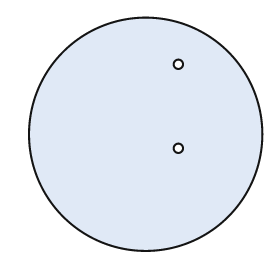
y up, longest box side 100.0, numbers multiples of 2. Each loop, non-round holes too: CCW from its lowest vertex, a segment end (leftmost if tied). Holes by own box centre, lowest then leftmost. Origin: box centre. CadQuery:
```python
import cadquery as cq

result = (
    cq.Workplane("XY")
    .moveTo(0.0, 0.0)
    .circle(50.0)
    .moveTo(14.0, -6.0)
    .circle(2.0)
    .moveTo(14.0, 30.0)
    .circle(2.0)
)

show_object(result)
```